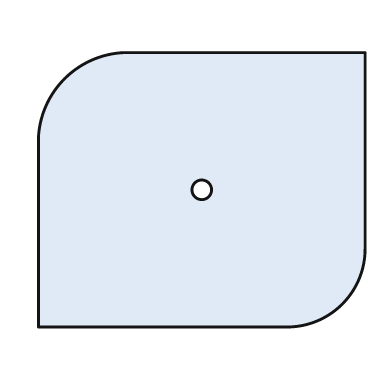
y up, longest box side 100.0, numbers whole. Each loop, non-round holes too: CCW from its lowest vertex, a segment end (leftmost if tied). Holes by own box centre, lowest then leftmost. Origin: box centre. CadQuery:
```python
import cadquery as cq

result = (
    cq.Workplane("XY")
    .moveTo(-50.0, -42.0)
    .lineTo(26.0, -42.0)
    .threePointArc((43.0, -35.0), (50.0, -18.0))
    .lineTo(50.0, 42.0)
    .lineTo(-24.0, 42.0)
    .threePointArc((-42.0, 34.0), (-50.0, 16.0))
    .close()
    .moveTo(0.0, 0.0)
    .circle(3.0)
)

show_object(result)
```